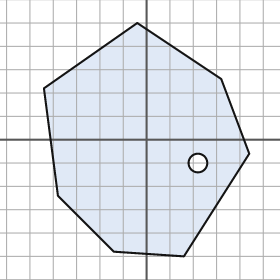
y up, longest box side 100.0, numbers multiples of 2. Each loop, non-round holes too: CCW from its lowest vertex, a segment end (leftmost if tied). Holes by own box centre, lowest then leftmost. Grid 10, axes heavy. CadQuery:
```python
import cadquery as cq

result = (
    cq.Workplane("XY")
    .moveTo(16.0, -50.0)
    .lineTo(44.0, -6.0)
    .lineTo(32.0, 26.0)
    .lineTo(-4.0, 50.0)
    .lineTo(-44.0, 22.0)
    .lineTo(-38.0, -24.0)
    .lineTo(-14.0, -48.0)
    .close()
    .moveTo(22.0, -10.0)
    .circle(4.0)
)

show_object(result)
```